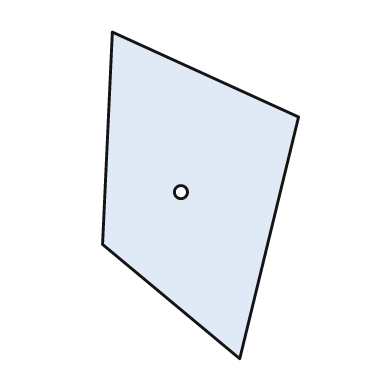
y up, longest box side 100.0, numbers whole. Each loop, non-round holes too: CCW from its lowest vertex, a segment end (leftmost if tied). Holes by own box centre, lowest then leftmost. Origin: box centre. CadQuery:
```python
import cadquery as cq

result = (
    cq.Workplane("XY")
    .moveTo(12.0, -50.0)
    .lineTo(30.0, 24.0)
    .lineTo(-27.0, 50.0)
    .lineTo(-30.0, -15.0)
    .close()
    .moveTo(-6.0, 1.0)
    .circle(2.0)
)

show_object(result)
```